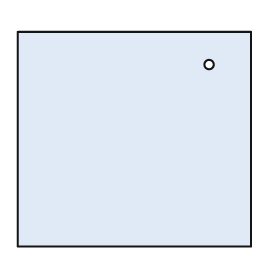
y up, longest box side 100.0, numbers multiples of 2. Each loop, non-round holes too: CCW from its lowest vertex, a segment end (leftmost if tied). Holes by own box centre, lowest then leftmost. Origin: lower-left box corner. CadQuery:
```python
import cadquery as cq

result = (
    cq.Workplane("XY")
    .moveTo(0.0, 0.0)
    .lineTo(100.0, 0.0)
    .lineTo(100.0, 92.0)
    .lineTo(0.0, 92.0)
    .close()
    .moveTo(82.0, 78.0)
    .circle(2.0)
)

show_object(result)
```